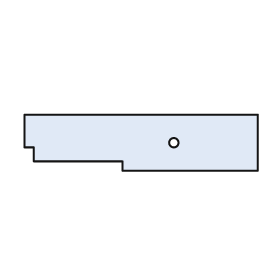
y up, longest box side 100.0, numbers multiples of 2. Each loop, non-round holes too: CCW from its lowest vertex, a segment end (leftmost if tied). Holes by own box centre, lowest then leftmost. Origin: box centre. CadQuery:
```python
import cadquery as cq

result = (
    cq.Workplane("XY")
    .moveTo(-8.0, -12.0)
    .lineTo(50.0, -12.0)
    .lineTo(50.0, 12.0)
    .lineTo(-50.0, 12.0)
    .lineTo(-50.0, -2.0)
    .lineTo(-46.0, -2.0)
    .lineTo(-46.0, -8.0)
    .lineTo(-8.0, -8.0)
    .close()
    .moveTo(14.0, 0.0)
    .circle(2.0)
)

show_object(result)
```